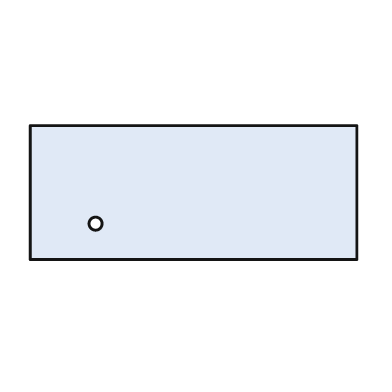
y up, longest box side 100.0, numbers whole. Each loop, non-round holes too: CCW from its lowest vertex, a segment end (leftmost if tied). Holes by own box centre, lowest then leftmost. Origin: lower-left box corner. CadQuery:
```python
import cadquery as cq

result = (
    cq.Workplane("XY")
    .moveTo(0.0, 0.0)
    .lineTo(100.0, 0.0)
    .lineTo(100.0, 41.0)
    .lineTo(0.0, 41.0)
    .close()
    .moveTo(20.0, 11.0)
    .circle(2.0)
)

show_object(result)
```